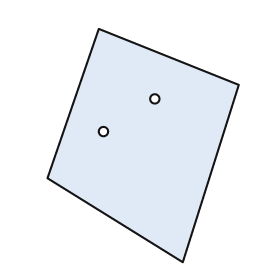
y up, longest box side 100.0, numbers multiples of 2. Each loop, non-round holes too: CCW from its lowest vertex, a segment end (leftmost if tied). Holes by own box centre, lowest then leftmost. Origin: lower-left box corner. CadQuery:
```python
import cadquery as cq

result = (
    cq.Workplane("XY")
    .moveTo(58.0, 0.0)
    .lineTo(82.0, 76.0)
    .lineTo(22.0, 100.0)
    .lineTo(0.0, 36.0)
    .close()
    .moveTo(24.0, 56.0)
    .circle(2.0)
    .moveTo(46.0, 70.0)
    .circle(2.0)
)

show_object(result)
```